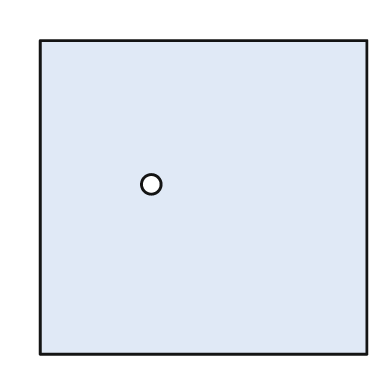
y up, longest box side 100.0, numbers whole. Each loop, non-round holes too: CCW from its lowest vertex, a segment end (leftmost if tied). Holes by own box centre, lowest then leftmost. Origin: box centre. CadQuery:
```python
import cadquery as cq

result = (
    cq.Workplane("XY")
    .moveTo(-50.0, -48.0)
    .lineTo(50.0, -48.0)
    .lineTo(50.0, 48.0)
    .lineTo(-50.0, 48.0)
    .close()
    .moveTo(-16.0, 4.0)
    .circle(3.0)
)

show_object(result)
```